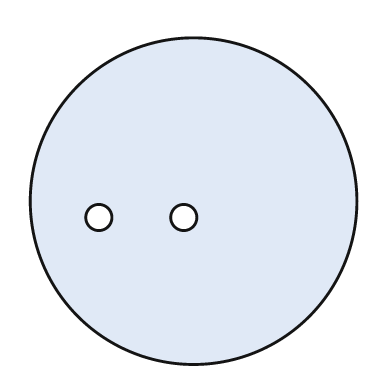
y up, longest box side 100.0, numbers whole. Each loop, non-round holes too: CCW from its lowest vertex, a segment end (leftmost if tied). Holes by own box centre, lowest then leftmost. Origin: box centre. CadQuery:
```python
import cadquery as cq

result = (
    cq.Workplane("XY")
    .moveTo(0.0, 0.0)
    .circle(50.0)
    .moveTo(-29.0, -5.0)
    .circle(4.0)
    .moveTo(-3.0, -5.0)
    .circle(4.0)
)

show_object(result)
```